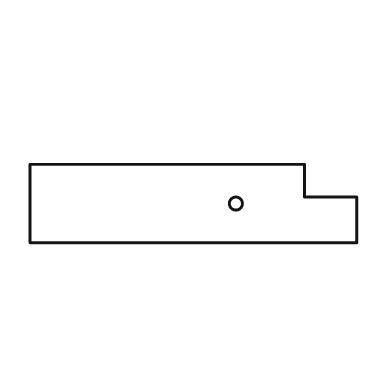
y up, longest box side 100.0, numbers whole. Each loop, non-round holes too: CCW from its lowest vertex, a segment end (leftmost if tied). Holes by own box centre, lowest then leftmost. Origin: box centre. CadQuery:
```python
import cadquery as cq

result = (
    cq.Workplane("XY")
    .moveTo(-50.0, -12.0)
    .lineTo(50.0, -12.0)
    .lineTo(50.0, 2.0)
    .lineTo(34.0, 2.0)
    .lineTo(34.0, 12.0)
    .lineTo(-50.0, 12.0)
    .close()
    .moveTo(13.0, 0.0)
    .circle(2.0)
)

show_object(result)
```